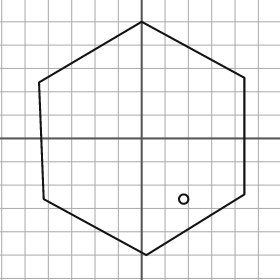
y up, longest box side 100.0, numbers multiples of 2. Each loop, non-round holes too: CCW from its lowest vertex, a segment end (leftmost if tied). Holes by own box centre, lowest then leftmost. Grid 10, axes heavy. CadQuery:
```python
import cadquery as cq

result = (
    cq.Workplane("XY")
    .moveTo(2.0, -50.0)
    .lineTo(44.0, -24.0)
    .lineTo(44.0, 26.0)
    .lineTo(0.0, 50.0)
    .lineTo(-44.0, 24.0)
    .lineTo(-42.0, -26.0)
    .close()
    .moveTo(18.0, -26.0)
    .circle(2.0)
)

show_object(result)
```